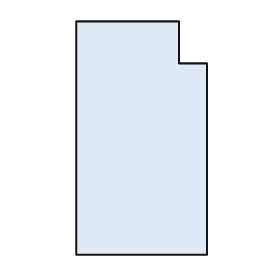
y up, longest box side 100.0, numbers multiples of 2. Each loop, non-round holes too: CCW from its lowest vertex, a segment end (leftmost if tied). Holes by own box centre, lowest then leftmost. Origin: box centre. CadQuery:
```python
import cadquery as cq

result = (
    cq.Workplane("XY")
    .moveTo(-28.0, -50.0)
    .lineTo(28.0, -50.0)
    .lineTo(28.0, 32.0)
    .lineTo(16.0, 32.0)
    .lineTo(16.0, 50.0)
    .lineTo(-28.0, 50.0)
    .close()
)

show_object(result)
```